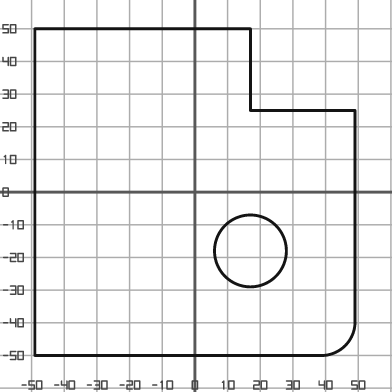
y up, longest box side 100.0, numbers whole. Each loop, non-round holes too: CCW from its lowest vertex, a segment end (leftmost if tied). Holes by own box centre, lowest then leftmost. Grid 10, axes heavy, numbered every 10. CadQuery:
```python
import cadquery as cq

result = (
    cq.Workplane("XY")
    .moveTo(-49.0, -50.0)
    .lineTo(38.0, -50.0)
    .threePointArc((46.0, -47.0), (49.0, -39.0))
    .lineTo(49.0, 25.0)
    .lineTo(17.0, 25.0)
    .lineTo(17.0, 50.0)
    .lineTo(-49.0, 50.0)
    .close()
    .moveTo(17.0, -18.0)
    .circle(11.0)
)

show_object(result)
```